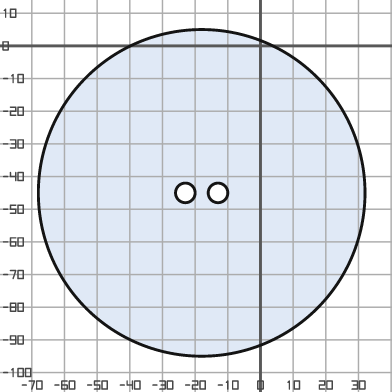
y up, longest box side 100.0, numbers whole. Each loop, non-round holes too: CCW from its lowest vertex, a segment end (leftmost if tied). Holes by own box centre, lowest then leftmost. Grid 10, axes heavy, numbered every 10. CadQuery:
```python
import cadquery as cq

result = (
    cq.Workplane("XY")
    .moveTo(-18.0, -45.0)
    .circle(50.0)
    .moveTo(-23.0, -45.0)
    .circle(3.0)
    .moveTo(-13.0, -45.0)
    .circle(3.0)
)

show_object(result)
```